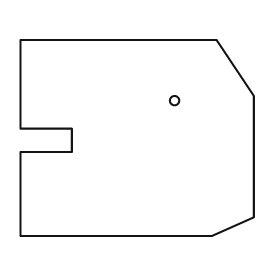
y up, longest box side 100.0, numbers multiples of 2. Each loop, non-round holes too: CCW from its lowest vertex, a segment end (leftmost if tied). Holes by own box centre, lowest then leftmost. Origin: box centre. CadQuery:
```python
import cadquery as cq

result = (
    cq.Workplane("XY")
    .moveTo(-50.0, -42.0)
    .lineTo(32.0, -42.0)
    .lineTo(50.0, -34.0)
    .lineTo(50.0, 18.0)
    .lineTo(34.0, 42.0)
    .lineTo(-50.0, 42.0)
    .lineTo(-50.0, 4.0)
    .lineTo(-28.0, 4.0)
    .lineTo(-28.0, -6.0)
    .lineTo(-50.0, -6.0)
    .close()
    .moveTo(16.0, 16.0)
    .circle(2.0)
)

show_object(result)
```